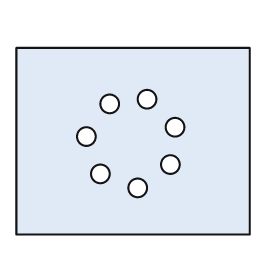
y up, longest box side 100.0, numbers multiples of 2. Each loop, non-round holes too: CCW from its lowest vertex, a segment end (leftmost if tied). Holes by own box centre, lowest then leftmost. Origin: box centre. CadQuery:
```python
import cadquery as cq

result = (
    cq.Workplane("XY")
    .moveTo(-50.0, -40.0)
    .lineTo(50.0, -40.0)
    .lineTo(50.0, 40.0)
    .lineTo(-50.0, 40.0)
    .close()
    .moveTo(2.0, -20.0)
    .circle(4.0)
    .moveTo(-14.0, -14.0)
    .circle(4.0)
    .moveTo(16.0, -10.0)
    .circle(4.0)
    .moveTo(-20.0, 2.0)
    .circle(4.0)
    .moveTo(18.0, 6.0)
    .circle(4.0)
    .moveTo(-10.0, 16.0)
    .circle(4.0)
    .moveTo(6.0, 18.0)
    .circle(4.0)
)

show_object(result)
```